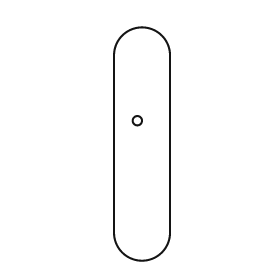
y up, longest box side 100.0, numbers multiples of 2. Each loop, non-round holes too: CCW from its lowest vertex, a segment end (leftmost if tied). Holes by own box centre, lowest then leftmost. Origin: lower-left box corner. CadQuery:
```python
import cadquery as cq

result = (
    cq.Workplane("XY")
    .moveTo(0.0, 12.0)
    .threePointArc((12.0, 0.0), (24.0, 12.0))
    .lineTo(24.0, 88.0)
    .threePointArc((12.0, 100.0), (0.0, 88.0))
    .close()
    .moveTo(10.0, 60.0)
    .circle(2.0)
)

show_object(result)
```